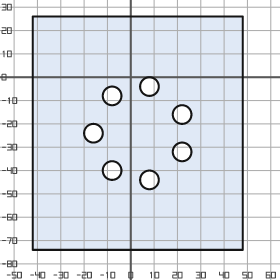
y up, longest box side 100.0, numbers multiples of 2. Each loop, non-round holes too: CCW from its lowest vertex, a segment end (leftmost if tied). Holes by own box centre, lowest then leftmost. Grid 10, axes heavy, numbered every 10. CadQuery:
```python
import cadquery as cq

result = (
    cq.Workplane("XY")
    .moveTo(-42.0, -74.0)
    .lineTo(48.0, -74.0)
    .lineTo(48.0, 26.0)
    .lineTo(-42.0, 26.0)
    .close()
    .moveTo(8.0, -44.0)
    .circle(4.0)
    .moveTo(-8.0, -40.0)
    .circle(4.0)
    .moveTo(22.0, -32.0)
    .circle(4.0)
    .moveTo(-16.0, -24.0)
    .circle(4.0)
    .moveTo(22.0, -16.0)
    .circle(4.0)
    .moveTo(-8.0, -8.0)
    .circle(4.0)
    .moveTo(8.0, -4.0)
    .circle(4.0)
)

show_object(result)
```